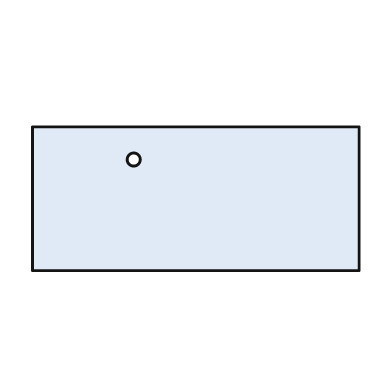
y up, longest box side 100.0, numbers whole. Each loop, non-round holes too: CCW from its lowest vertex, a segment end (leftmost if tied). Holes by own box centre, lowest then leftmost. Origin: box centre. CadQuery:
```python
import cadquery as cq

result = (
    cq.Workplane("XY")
    .moveTo(-50.0, -22.0)
    .lineTo(50.0, -22.0)
    .lineTo(50.0, 22.0)
    .lineTo(-50.0, 22.0)
    .close()
    .moveTo(-19.0, 12.0)
    .circle(2.0)
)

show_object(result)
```